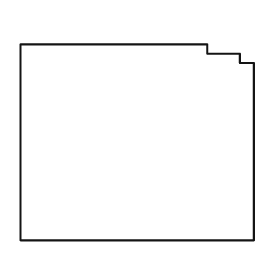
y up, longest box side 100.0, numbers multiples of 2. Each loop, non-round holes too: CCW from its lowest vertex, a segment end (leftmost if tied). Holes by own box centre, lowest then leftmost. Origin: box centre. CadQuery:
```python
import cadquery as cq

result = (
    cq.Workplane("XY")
    .moveTo(-50.0, -42.0)
    .lineTo(50.0, -42.0)
    .lineTo(50.0, 34.0)
    .lineTo(44.0, 34.0)
    .lineTo(44.0, 38.0)
    .lineTo(30.0, 38.0)
    .lineTo(30.0, 42.0)
    .lineTo(-50.0, 42.0)
    .close()
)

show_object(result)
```